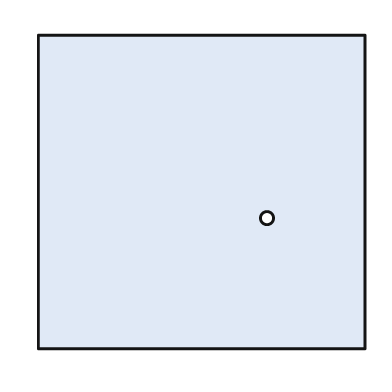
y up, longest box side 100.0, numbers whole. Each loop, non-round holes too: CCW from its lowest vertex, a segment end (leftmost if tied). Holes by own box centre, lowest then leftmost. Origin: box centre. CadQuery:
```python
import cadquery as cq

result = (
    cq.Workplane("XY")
    .moveTo(-50.0, -48.0)
    .lineTo(50.0, -48.0)
    .lineTo(50.0, 48.0)
    .lineTo(-50.0, 48.0)
    .close()
    .moveTo(20.0, -8.0)
    .circle(2.0)
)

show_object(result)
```